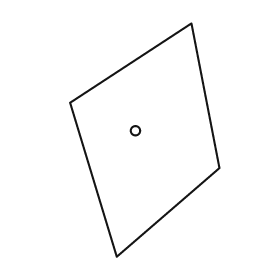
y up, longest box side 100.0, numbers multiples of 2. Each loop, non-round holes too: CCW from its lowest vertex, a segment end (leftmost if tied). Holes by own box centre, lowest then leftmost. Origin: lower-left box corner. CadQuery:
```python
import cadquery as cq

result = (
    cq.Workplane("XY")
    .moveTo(20.0, 0.0)
    .lineTo(64.0, 38.0)
    .lineTo(52.0, 100.0)
    .lineTo(0.0, 66.0)
    .close()
    .moveTo(28.0, 54.0)
    .circle(2.0)
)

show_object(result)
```